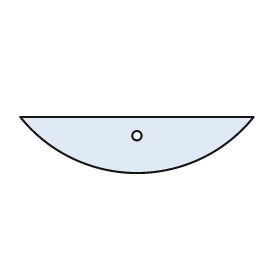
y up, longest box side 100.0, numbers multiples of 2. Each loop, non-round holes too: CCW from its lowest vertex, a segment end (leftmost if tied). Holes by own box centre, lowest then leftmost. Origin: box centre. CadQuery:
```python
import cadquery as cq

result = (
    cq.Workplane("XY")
    .moveTo(-50.0, 12.0)
    .threePointArc((0.0, -12.0), (50.0, 12.0))
    .close()
    .moveTo(0.0, 4.0)
    .circle(2.0)
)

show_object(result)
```